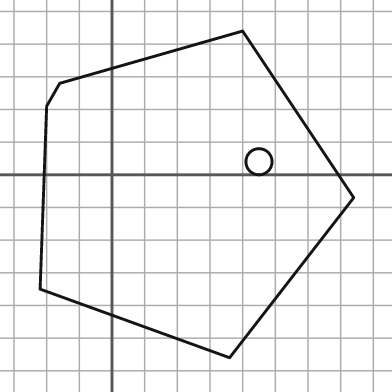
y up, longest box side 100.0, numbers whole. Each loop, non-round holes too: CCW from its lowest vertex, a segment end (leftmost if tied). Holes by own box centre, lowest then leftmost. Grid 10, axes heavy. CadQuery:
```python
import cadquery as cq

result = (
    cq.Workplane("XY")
    .moveTo(36.0, -56.0)
    .lineTo(74.0, -7.0)
    .lineTo(40.0, 44.0)
    .lineTo(-16.0, 28.0)
    .lineTo(-20.0, 21.0)
    .lineTo(-22.0, -35.0)
    .close()
    .moveTo(45.0, 4.0)
    .circle(4.0)
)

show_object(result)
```